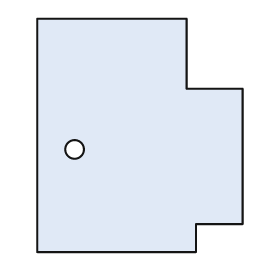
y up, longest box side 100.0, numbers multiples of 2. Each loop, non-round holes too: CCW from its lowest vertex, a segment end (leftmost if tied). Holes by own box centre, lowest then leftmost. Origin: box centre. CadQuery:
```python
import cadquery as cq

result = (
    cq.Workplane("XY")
    .moveTo(-44.0, -50.0)
    .lineTo(24.0, -50.0)
    .lineTo(24.0, -38.0)
    .lineTo(44.0, -38.0)
    .lineTo(44.0, 20.0)
    .lineTo(20.0, 20.0)
    .lineTo(20.0, 50.0)
    .lineTo(-44.0, 50.0)
    .close()
    .moveTo(-28.0, -6.0)
    .circle(4.0)
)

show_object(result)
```